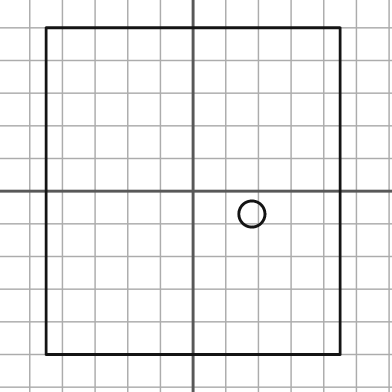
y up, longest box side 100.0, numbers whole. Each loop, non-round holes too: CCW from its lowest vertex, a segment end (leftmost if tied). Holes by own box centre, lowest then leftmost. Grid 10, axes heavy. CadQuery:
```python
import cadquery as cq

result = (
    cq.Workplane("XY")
    .moveTo(-45.0, -50.0)
    .lineTo(45.0, -50.0)
    .lineTo(45.0, 50.0)
    .lineTo(-45.0, 50.0)
    .close()
    .moveTo(18.0, -7.0)
    .circle(4.0)
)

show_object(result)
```